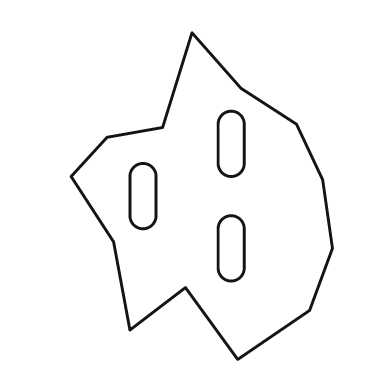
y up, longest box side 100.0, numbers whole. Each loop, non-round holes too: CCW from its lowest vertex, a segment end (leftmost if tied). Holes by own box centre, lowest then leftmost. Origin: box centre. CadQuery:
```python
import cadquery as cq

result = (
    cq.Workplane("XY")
    .moveTo(11.0, -50.0)
    .lineTo(33.0, -35.0)
    .lineTo(40.0, -16.0)
    .lineTo(37.0, 5.0)
    .lineTo(29.0, 22.0)
    .lineTo(12.0, 33.0)
    .lineTo(-3.0, 50.0)
    .lineTo(-12.0, 21.0)
    .lineTo(-29.0, 18.0)
    .lineTo(-40.0, 6.0)
    .lineTo(-27.0, -14.0)
    .lineTo(-22.0, -41.0)
    .lineTo(-5.0, -28.0)
    .close()
    .moveTo(5.0, -22.0)
    .threePointArc((9.0, -26.0), (13.0, -22.0))
    .lineTo(13.0, -10.0)
    .threePointArc((9.0, -6.0), (5.0, -10.0))
    .close()
    .moveTo(-22.0, -6.0)
    .threePointArc((-18.0, -10.0), (-14.0, -6.0))
    .lineTo(-14.0, 6.0)
    .threePointArc((-18.0, 10.0), (-22.0, 6.0))
    .close()
    .moveTo(5.0, 10.0)
    .threePointArc((9.0, 6.0), (13.0, 10.0))
    .lineTo(13.0, 22.0)
    .threePointArc((9.0, 26.0), (5.0, 22.0))
    .close()
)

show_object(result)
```